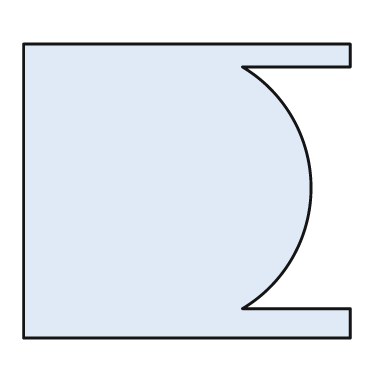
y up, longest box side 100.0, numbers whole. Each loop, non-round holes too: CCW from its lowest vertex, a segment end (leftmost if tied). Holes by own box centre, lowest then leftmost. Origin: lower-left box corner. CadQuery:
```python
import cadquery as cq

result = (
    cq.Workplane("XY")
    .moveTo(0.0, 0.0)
    .lineTo(100.0, 0.0)
    .lineTo(100.0, 9.0)
    .lineTo(67.0, 9.0)
    .threePointArc((88.0, 46.0), (67.0, 83.0))
    .lineTo(100.0, 83.0)
    .lineTo(100.0, 90.0)
    .lineTo(0.0, 90.0)
    .close()
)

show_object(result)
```